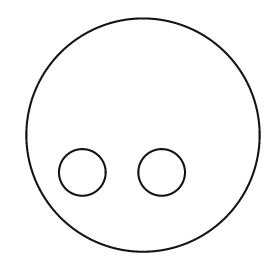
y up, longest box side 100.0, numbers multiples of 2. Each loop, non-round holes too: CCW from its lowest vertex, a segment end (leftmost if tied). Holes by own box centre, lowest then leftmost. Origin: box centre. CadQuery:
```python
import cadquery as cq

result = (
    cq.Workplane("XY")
    .moveTo(0.0, 0.0)
    .circle(50.0)
    .moveTo(-26.0, -16.0)
    .circle(10.0)
    .moveTo(8.0, -16.0)
    .circle(10.0)
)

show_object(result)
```